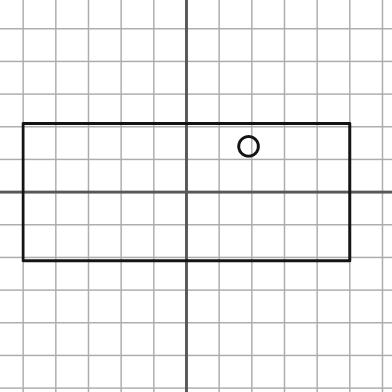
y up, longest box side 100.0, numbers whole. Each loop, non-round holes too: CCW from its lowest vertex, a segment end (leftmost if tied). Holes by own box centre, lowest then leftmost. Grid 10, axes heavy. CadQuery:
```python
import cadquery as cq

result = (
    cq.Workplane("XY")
    .moveTo(-50.0, -21.0)
    .lineTo(50.0, -21.0)
    .lineTo(50.0, 21.0)
    .lineTo(-50.0, 21.0)
    .close()
    .moveTo(19.0, 14.0)
    .circle(3.0)
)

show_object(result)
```